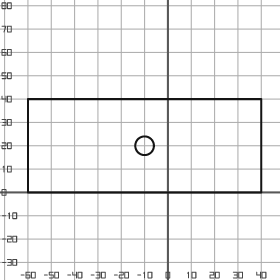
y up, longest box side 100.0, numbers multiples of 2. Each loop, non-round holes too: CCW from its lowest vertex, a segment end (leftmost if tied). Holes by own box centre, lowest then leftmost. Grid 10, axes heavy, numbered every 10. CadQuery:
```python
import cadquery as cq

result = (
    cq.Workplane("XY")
    .moveTo(-60.0, 0.0)
    .lineTo(40.0, 0.0)
    .lineTo(40.0, 40.0)
    .lineTo(-60.0, 40.0)
    .close()
    .moveTo(-10.0, 20.0)
    .circle(4.0)
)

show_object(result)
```